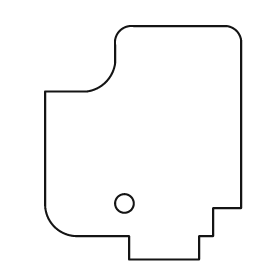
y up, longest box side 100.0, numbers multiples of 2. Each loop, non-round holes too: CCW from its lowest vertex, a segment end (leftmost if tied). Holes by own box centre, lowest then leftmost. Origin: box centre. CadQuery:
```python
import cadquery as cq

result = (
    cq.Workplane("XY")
    .moveTo(-6.0, -50.0)
    .lineTo(24.0, -50.0)
    .lineTo(24.0, -40.0)
    .lineTo(30.0, -40.0)
    .lineTo(30.0, -28.0)
    .lineTo(42.0, -28.0)
    .lineTo(42.0, 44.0)
    .threePointArc((40.0, 48.0), (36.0, 50.0))
    .lineTo(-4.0, 50.0)
    .threePointArc((-10.0, 48.0), (-12.0, 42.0))
    .lineTo(-12.0, 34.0)
    .threePointArc((-16.0, 26.0), (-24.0, 22.0))
    .lineTo(-42.0, 22.0)
    .lineTo(-42.0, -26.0)
    .threePointArc((-38.0, -36.0), (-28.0, -40.0))
    .lineTo(-6.0, -40.0)
    .close()
    .moveTo(-8.0, -26.0)
    .circle(4.0)
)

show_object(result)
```